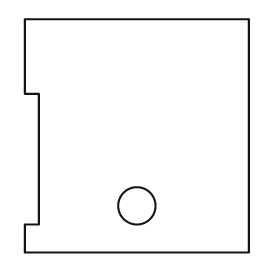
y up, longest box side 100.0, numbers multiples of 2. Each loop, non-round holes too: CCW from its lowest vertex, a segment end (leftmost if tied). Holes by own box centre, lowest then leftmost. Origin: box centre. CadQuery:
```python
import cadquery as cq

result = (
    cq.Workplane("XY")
    .moveTo(-48.0, -50.0)
    .lineTo(48.0, -50.0)
    .lineTo(48.0, 50.0)
    .lineTo(-48.0, 50.0)
    .lineTo(-48.0, 18.0)
    .lineTo(-42.0, 18.0)
    .lineTo(-42.0, -38.0)
    .lineTo(-48.0, -38.0)
    .close()
    .moveTo(0.0, -30.0)
    .circle(8.0)
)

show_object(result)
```